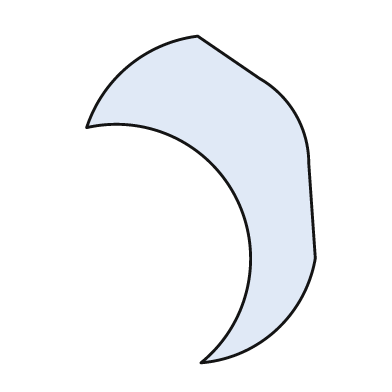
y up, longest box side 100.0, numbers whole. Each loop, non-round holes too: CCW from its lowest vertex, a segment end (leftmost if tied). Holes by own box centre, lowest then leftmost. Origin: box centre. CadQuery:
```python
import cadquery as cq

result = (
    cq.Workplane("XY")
    .moveTo(0.0, -50.0)
    .threePointArc((23.0, -40.0), (35.0, -18.0))
    .lineTo(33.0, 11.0)
    .threePointArc((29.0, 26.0), (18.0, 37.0))
    .lineTo(-1.0, 50.0)
    .threePointArc((-22.0, 41.0), (-35.0, 22.0))
    .threePointArc((11.0, 0.0), (0.0, -50.0))
    .close()
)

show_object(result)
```